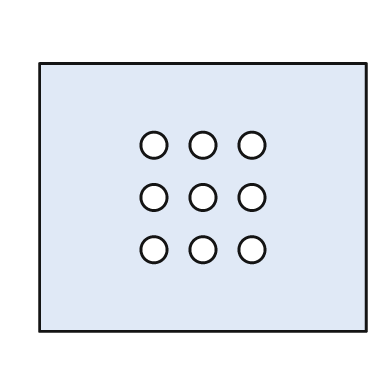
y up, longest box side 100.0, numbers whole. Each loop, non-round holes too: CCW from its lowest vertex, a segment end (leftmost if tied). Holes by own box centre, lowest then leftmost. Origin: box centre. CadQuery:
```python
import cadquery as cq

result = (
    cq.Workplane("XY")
    .moveTo(-50.0, -41.0)
    .lineTo(50.0, -41.0)
    .lineTo(50.0, 41.0)
    .lineTo(-50.0, 41.0)
    .close()
    .moveTo(-15.0, -16.0)
    .circle(4.0)
    .moveTo(0.0, -16.0)
    .circle(4.0)
    .moveTo(15.0, -16.0)
    .circle(4.0)
    .moveTo(-15.0, 0.0)
    .circle(4.0)
    .moveTo(0.0, 0.0)
    .circle(4.0)
    .moveTo(15.0, 0.0)
    .circle(4.0)
    .moveTo(-15.0, 16.0)
    .circle(4.0)
    .moveTo(0.0, 16.0)
    .circle(4.0)
    .moveTo(15.0, 16.0)
    .circle(4.0)
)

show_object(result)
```